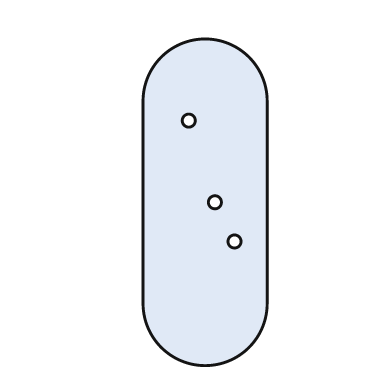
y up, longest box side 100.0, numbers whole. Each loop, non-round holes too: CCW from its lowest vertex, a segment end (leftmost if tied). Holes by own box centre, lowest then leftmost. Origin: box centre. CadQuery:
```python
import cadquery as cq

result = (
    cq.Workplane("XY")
    .moveTo(-19.0, -31.0)
    .threePointArc((0.0, -50.0), (19.0, -31.0))
    .lineTo(19.0, 31.0)
    .threePointArc((0.0, 50.0), (-19.0, 31.0))
    .close()
    .moveTo(9.0, -12.0)
    .circle(2.0)
    .moveTo(3.0, 0.0)
    .circle(2.0)
    .moveTo(-5.0, 25.0)
    .circle(2.0)
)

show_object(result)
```